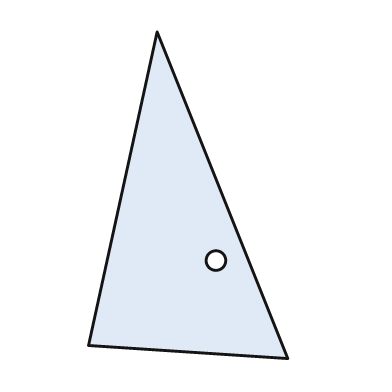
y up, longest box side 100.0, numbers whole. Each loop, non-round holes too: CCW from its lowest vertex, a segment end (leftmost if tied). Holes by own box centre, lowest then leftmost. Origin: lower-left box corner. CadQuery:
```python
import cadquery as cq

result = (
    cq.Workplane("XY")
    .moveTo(61.0, 0.0)
    .lineTo(21.0, 100.0)
    .lineTo(0.0, 4.0)
    .close()
    .moveTo(39.0, 30.0)
    .circle(3.0)
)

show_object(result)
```